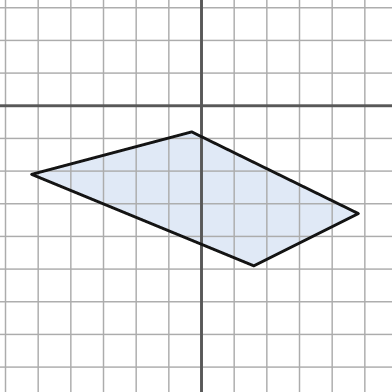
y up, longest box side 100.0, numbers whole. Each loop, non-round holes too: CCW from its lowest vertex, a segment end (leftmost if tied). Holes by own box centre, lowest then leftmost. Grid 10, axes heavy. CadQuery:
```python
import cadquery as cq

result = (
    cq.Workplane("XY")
    .moveTo(16.0, -49.0)
    .lineTo(48.0, -33.0)
    .lineTo(-3.0, -8.0)
    .lineTo(-52.0, -21.0)
    .close()
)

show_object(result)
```